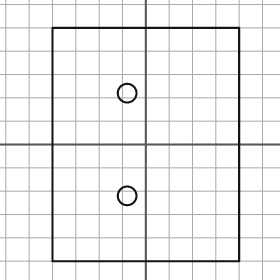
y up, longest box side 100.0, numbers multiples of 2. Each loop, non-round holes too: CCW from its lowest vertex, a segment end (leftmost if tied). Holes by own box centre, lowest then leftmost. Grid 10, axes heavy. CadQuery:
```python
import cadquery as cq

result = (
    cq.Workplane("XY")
    .moveTo(-40.0, -50.0)
    .lineTo(40.0, -50.0)
    .lineTo(40.0, 50.0)
    .lineTo(-40.0, 50.0)
    .close()
    .moveTo(-8.0, -22.0)
    .circle(4.0)
    .moveTo(-8.0, 22.0)
    .circle(4.0)
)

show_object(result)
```